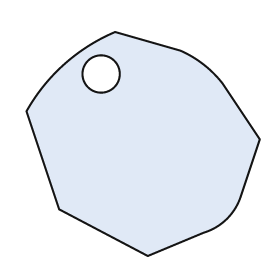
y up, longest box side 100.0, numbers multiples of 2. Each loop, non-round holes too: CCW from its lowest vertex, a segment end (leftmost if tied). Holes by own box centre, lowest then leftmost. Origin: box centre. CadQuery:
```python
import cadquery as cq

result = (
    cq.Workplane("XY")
    .moveTo(2.0, -48.0)
    .lineTo(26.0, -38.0)
    .threePointArc((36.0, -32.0), (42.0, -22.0))
    .lineTo(50.0, 2.0)
    .lineTo(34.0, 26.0)
    .threePointArc((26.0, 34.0), (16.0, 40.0))
    .lineTo(-12.0, 48.0)
    .threePointArc((-34.0, 34.0), (-50.0, 14.0))
    .lineTo(-36.0, -28.0)
    .close()
    .moveTo(-18.0, 30.0)
    .circle(8.0)
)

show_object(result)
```